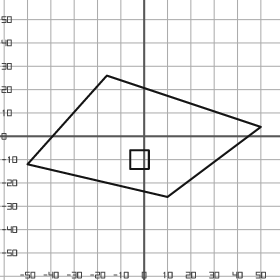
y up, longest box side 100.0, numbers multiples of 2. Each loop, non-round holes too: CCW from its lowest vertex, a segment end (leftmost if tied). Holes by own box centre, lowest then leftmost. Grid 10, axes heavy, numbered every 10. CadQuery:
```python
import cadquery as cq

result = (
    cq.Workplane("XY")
    .moveTo(10.0, -26.0)
    .lineTo(50.0, 4.0)
    .lineTo(-16.0, 26.0)
    .lineTo(-50.0, -12.0)
    .close()
    .moveTo(-6.0, -14.0)
    .lineTo(2.0, -14.0)
    .lineTo(2.0, -6.0)
    .lineTo(-6.0, -6.0)
    .close()
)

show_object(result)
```